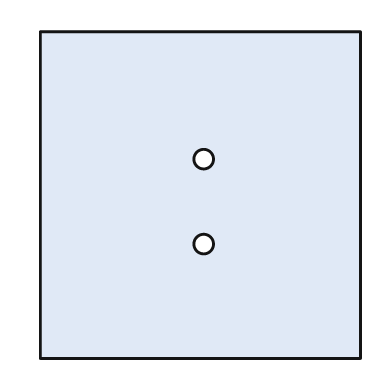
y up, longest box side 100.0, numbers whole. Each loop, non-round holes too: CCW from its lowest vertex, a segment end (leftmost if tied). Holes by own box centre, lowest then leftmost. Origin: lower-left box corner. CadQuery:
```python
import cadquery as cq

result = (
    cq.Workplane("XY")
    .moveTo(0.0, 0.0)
    .lineTo(98.0, 0.0)
    .lineTo(98.0, 100.0)
    .lineTo(0.0, 100.0)
    .close()
    .moveTo(50.0, 35.0)
    .circle(3.0)
    .moveTo(50.0, 61.0)
    .circle(3.0)
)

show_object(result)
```